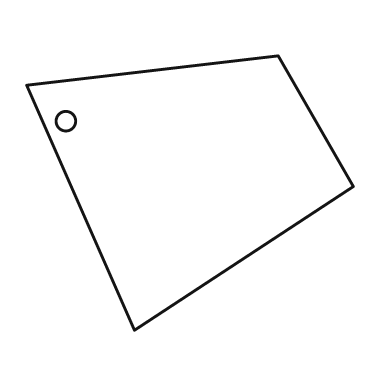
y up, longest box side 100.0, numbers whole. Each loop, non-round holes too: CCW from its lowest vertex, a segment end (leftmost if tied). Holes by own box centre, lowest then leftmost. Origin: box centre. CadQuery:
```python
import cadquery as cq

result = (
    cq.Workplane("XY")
    .moveTo(-17.0, -42.0)
    .lineTo(50.0, 2.0)
    .lineTo(27.0, 42.0)
    .lineTo(-50.0, 33.0)
    .close()
    .moveTo(-38.0, 22.0)
    .circle(3.0)
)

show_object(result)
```